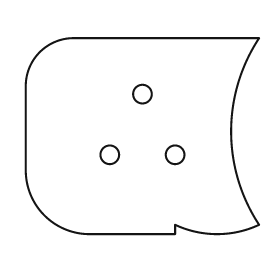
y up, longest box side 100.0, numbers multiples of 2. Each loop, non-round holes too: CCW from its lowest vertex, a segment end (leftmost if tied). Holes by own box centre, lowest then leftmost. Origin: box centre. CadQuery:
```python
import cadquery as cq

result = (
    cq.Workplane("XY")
    .moveTo(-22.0, -42.0)
    .lineTo(14.0, -42.0)
    .lineTo(14.0, -38.0)
    .threePointArc((32.0, -42.0), (50.0, -38.0))
    .threePointArc((38.0, 2.0), (50.0, 42.0))
    .lineTo(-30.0, 42.0)
    .threePointArc((-44.0, 36.0), (-50.0, 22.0))
    .lineTo(-50.0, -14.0)
    .threePointArc((-42.0, -34.0), (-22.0, -42.0))
    .close()
    .moveTo(-14.0, -8.0)
    .circle(4.0)
    .moveTo(14.0, -8.0)
    .circle(4.0)
    .moveTo(0.0, 18.0)
    .circle(4.0)
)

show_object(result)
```